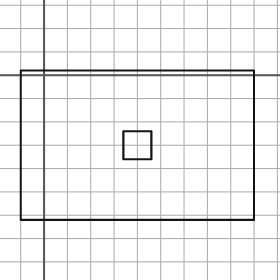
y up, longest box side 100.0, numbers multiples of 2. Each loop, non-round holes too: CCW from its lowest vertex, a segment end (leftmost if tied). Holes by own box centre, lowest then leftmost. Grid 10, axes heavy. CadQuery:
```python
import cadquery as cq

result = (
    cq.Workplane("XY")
    .moveTo(-10.0, -62.0)
    .lineTo(90.0, -62.0)
    .lineTo(90.0, 2.0)
    .lineTo(-10.0, 2.0)
    .close()
    .moveTo(34.0, -36.0)
    .lineTo(46.0, -36.0)
    .lineTo(46.0, -24.0)
    .lineTo(34.0, -24.0)
    .close()
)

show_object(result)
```